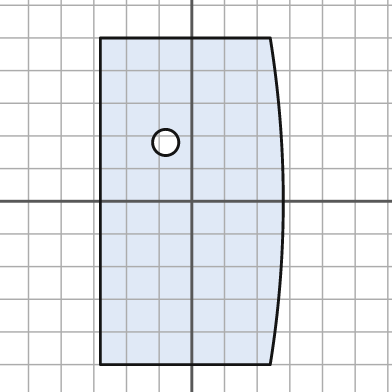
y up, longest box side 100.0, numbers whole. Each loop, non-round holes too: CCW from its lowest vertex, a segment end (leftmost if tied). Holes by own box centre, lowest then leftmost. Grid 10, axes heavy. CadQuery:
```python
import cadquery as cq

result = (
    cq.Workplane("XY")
    .moveTo(-28.0, -50.0)
    .lineTo(24.0, -50.0)
    .threePointArc((28.0, 0.0), (24.0, 50.0))
    .lineTo(-28.0, 50.0)
    .close()
    .moveTo(-8.0, 18.0)
    .circle(4.0)
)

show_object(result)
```